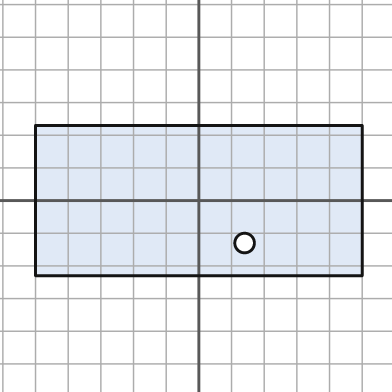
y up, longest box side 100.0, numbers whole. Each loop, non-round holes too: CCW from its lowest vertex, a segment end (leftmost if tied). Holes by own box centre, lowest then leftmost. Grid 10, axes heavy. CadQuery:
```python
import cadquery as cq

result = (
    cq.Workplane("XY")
    .moveTo(-50.0, -23.0)
    .lineTo(50.0, -23.0)
    .lineTo(50.0, 23.0)
    .lineTo(-50.0, 23.0)
    .close()
    .moveTo(14.0, -13.0)
    .circle(3.0)
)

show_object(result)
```